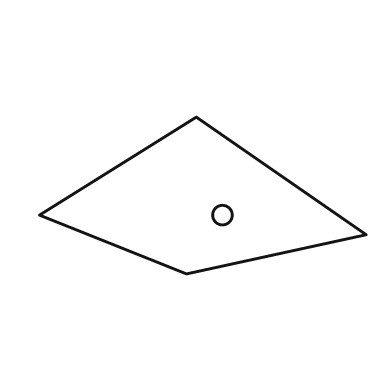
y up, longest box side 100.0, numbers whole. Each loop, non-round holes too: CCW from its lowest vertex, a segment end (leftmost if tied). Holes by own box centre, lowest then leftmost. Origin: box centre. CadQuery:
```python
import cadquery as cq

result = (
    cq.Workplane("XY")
    .moveTo(-5.0, -24.0)
    .lineTo(50.0, -12.0)
    .lineTo(-2.0, 24.0)
    .lineTo(-50.0, -6.0)
    .close()
    .moveTo(6.0, -6.0)
    .circle(3.0)
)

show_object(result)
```